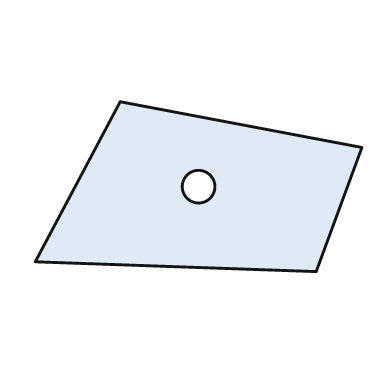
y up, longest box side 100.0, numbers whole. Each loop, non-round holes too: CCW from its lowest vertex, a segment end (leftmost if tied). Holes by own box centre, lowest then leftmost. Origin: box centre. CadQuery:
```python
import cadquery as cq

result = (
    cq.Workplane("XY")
    .moveTo(36.0, -26.0)
    .lineTo(50.0, 12.0)
    .lineTo(-24.0, 26.0)
    .lineTo(-50.0, -23.0)
    .close()
    .moveTo(0.0, 0.0)
    .circle(5.0)
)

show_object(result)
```